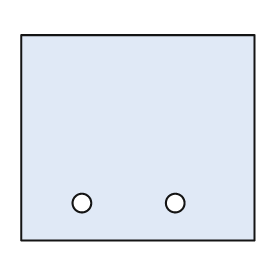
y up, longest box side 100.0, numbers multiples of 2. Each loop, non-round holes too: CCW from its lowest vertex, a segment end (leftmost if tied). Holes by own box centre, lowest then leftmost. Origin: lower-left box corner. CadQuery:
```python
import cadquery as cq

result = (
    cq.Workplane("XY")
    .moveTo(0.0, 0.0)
    .lineTo(100.0, 0.0)
    .lineTo(100.0, 88.0)
    .lineTo(0.0, 88.0)
    .close()
    .moveTo(26.0, 16.0)
    .circle(4.0)
    .moveTo(66.0, 16.0)
    .circle(4.0)
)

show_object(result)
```